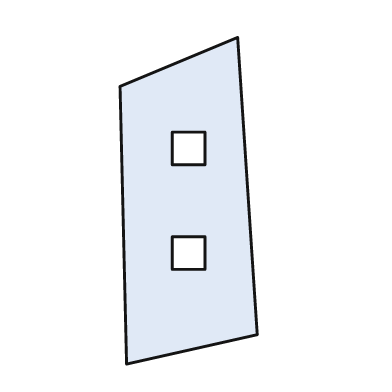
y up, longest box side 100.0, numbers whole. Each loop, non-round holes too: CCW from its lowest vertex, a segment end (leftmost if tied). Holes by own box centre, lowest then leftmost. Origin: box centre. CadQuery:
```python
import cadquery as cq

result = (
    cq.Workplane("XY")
    .moveTo(-19.0, -50.0)
    .lineTo(21.0, -41.0)
    .lineTo(15.0, 50.0)
    .lineTo(-21.0, 35.0)
    .close()
    .moveTo(-5.0, -21.0)
    .lineTo(5.0, -21.0)
    .lineTo(5.0, -11.0)
    .lineTo(-5.0, -11.0)
    .close()
    .moveTo(-5.0, 11.0)
    .lineTo(5.0, 11.0)
    .lineTo(5.0, 21.0)
    .lineTo(-5.0, 21.0)
    .close()
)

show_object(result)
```